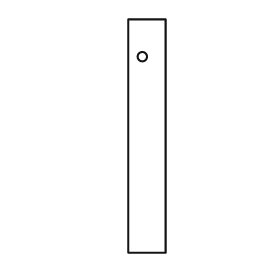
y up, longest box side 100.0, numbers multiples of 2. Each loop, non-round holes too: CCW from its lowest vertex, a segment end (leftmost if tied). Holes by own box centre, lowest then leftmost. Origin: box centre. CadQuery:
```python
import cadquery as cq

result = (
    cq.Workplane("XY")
    .moveTo(-8.0, -50.0)
    .lineTo(8.0, -50.0)
    .lineTo(8.0, 50.0)
    .lineTo(-8.0, 50.0)
    .close()
    .moveTo(-2.0, 34.0)
    .circle(2.0)
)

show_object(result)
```